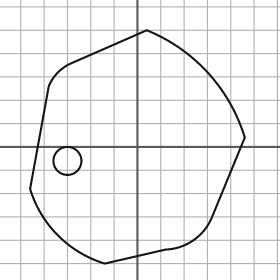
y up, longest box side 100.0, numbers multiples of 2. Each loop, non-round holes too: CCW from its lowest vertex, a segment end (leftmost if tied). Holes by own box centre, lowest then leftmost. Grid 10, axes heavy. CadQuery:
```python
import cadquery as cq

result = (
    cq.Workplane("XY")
    .moveTo(-14.0, -50.0)
    .lineTo(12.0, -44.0)
    .threePointArc((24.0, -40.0), (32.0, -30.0))
    .lineTo(46.0, 4.0)
    .threePointArc((30.0, 32.0), (4.0, 50.0))
    .lineTo(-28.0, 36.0)
    .threePointArc((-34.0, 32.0), (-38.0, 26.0))
    .lineTo(-46.0, -18.0)
    .threePointArc((-34.0, -38.0), (-14.0, -50.0))
    .close()
    .moveTo(-30.0, -6.0)
    .circle(6.0)
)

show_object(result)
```